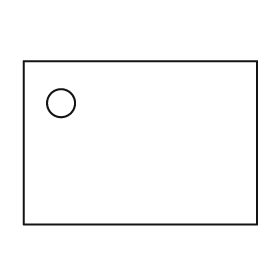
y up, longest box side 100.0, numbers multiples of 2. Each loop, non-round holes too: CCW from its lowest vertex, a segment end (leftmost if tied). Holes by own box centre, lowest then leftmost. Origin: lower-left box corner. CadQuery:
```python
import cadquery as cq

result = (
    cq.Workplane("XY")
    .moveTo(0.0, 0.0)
    .lineTo(100.0, 0.0)
    .lineTo(100.0, 70.0)
    .lineTo(0.0, 70.0)
    .close()
    .moveTo(16.0, 52.0)
    .circle(6.0)
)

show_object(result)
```